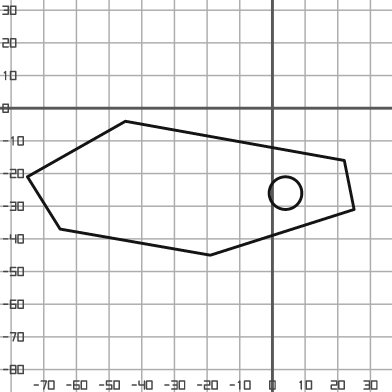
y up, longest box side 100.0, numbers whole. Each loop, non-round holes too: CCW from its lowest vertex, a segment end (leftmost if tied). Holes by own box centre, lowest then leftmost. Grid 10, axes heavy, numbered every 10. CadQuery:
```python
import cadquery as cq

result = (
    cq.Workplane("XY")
    .moveTo(-19.0, -45.0)
    .lineTo(25.0, -31.0)
    .lineTo(22.0, -16.0)
    .lineTo(-45.0, -4.0)
    .lineTo(-75.0, -21.0)
    .lineTo(-65.0, -37.0)
    .close()
    .moveTo(4.0, -26.0)
    .circle(5.0)
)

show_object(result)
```